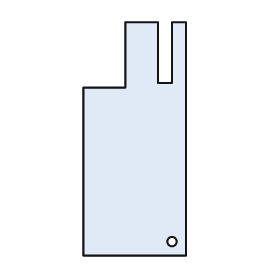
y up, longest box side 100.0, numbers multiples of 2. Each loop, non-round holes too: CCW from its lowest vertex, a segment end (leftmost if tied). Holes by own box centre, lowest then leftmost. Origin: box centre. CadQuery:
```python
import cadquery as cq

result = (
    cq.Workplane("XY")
    .moveTo(-22.0, -50.0)
    .lineTo(22.0, -50.0)
    .lineTo(22.0, 50.0)
    .lineTo(16.0, 50.0)
    .lineTo(16.0, 24.0)
    .lineTo(10.0, 24.0)
    .lineTo(10.0, 50.0)
    .lineTo(-4.0, 50.0)
    .lineTo(-4.0, 22.0)
    .lineTo(-22.0, 22.0)
    .close()
    .moveTo(16.0, -44.0)
    .circle(2.0)
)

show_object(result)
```